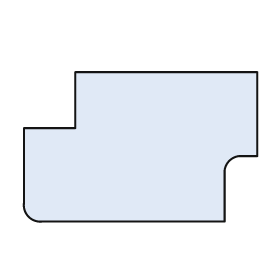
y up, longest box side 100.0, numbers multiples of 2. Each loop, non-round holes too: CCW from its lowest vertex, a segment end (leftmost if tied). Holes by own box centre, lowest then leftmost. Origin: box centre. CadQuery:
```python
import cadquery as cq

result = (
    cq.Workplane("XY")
    .moveTo(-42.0, -32.0)
    .lineTo(36.0, -32.0)
    .lineTo(36.0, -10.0)
    .threePointArc((38.0, -6.0), (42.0, -4.0))
    .lineTo(50.0, -4.0)
    .lineTo(50.0, 32.0)
    .lineTo(-28.0, 32.0)
    .lineTo(-28.0, 8.0)
    .lineTo(-50.0, 8.0)
    .lineTo(-50.0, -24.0)
    .threePointArc((-48.0, -30.0), (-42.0, -32.0))
    .close()
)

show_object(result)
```